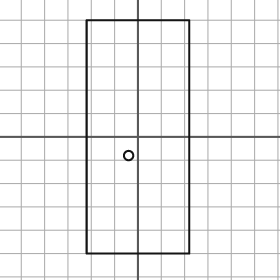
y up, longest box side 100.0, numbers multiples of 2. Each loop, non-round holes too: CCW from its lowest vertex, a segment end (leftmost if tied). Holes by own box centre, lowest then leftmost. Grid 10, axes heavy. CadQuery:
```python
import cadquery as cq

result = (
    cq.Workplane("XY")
    .moveTo(-22.0, -50.0)
    .lineTo(22.0, -50.0)
    .lineTo(22.0, 50.0)
    .lineTo(-22.0, 50.0)
    .close()
    .moveTo(-4.0, -8.0)
    .circle(2.0)
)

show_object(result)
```